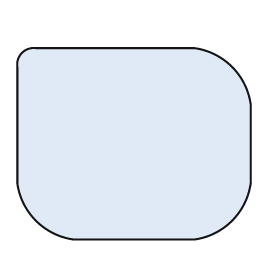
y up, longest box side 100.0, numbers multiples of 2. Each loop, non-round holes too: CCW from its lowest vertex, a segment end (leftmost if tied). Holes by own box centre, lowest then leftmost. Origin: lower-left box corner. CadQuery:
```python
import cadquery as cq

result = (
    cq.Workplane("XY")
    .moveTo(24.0, 0.0)
    .lineTo(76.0, 0.0)
    .threePointArc((92.0, 8.0), (100.0, 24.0))
    .lineTo(100.0, 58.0)
    .threePointArc((92.0, 74.0), (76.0, 82.0))
    .lineTo(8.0, 82.0)
    .threePointArc((2.0, 80.0), (0.0, 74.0))
    .lineTo(0.0, 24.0)
    .threePointArc((8.0, 8.0), (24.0, 0.0))
    .close()
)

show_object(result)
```